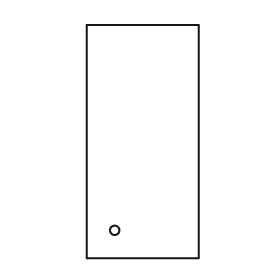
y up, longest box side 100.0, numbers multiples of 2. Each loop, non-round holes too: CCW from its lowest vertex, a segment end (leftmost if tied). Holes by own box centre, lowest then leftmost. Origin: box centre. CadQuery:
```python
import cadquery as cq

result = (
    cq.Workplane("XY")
    .moveTo(-24.0, -50.0)
    .lineTo(24.0, -50.0)
    .lineTo(24.0, 50.0)
    .lineTo(-24.0, 50.0)
    .close()
    .moveTo(-12.0, -38.0)
    .circle(2.0)
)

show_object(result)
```